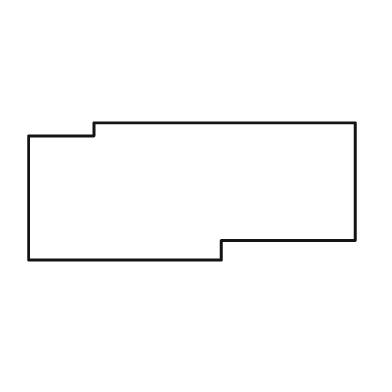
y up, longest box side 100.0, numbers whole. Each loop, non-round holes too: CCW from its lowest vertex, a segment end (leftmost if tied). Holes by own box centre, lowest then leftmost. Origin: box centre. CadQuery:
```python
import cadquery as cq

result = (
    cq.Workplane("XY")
    .moveTo(-50.0, -21.0)
    .lineTo(9.0, -21.0)
    .lineTo(9.0, -15.0)
    .lineTo(50.0, -15.0)
    .lineTo(50.0, 21.0)
    .lineTo(-30.0, 21.0)
    .lineTo(-30.0, 17.0)
    .lineTo(-50.0, 17.0)
    .close()
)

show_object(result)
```